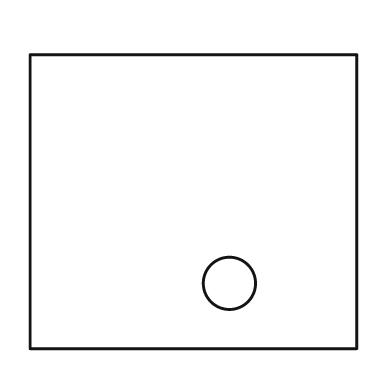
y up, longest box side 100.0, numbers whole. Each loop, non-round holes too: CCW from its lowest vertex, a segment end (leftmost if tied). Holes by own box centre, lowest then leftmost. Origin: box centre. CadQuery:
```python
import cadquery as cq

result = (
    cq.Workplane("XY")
    .moveTo(-50.0, -45.0)
    .lineTo(50.0, -45.0)
    .lineTo(50.0, 45.0)
    .lineTo(-50.0, 45.0)
    .close()
    .moveTo(11.0, -25.0)
    .circle(8.0)
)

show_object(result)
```